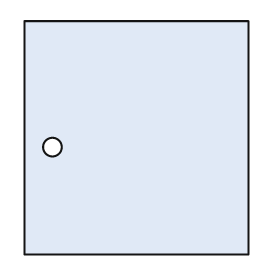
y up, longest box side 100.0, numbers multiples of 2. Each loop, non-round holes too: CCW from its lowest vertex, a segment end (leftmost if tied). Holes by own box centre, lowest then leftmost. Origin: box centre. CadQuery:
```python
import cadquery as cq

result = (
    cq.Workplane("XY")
    .moveTo(-48.0, -50.0)
    .lineTo(48.0, -50.0)
    .lineTo(48.0, 50.0)
    .lineTo(-48.0, 50.0)
    .close()
    .moveTo(-36.0, -4.0)
    .circle(4.0)
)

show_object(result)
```